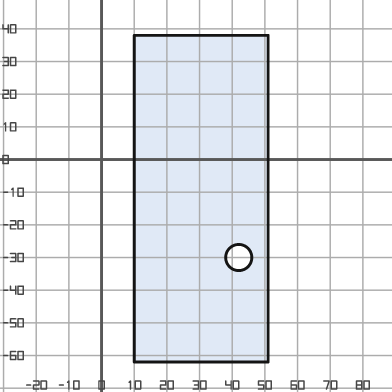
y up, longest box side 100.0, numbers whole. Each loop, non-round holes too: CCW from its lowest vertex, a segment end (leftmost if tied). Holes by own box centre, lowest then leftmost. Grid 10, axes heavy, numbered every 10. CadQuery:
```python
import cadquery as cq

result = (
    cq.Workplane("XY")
    .moveTo(10.0, -62.0)
    .lineTo(51.0, -62.0)
    .lineTo(51.0, 38.0)
    .lineTo(10.0, 38.0)
    .close()
    .moveTo(42.0, -30.0)
    .circle(4.0)
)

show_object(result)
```